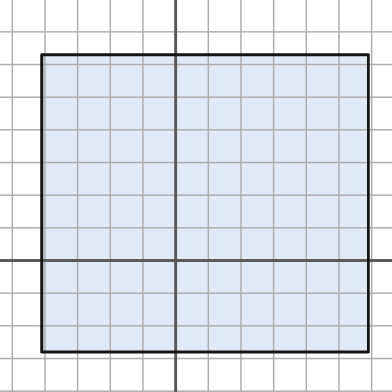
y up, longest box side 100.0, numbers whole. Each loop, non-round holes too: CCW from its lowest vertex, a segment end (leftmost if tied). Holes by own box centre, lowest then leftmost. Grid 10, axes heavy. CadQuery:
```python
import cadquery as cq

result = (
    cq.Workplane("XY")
    .moveTo(-41.0, -28.0)
    .lineTo(59.0, -28.0)
    .lineTo(59.0, 63.0)
    .lineTo(-41.0, 63.0)
    .close()
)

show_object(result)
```